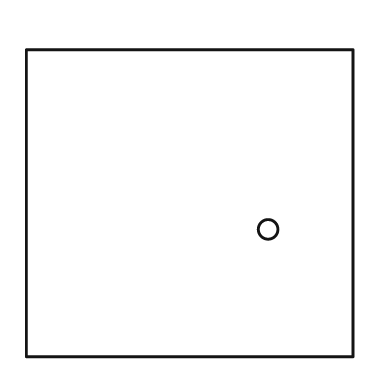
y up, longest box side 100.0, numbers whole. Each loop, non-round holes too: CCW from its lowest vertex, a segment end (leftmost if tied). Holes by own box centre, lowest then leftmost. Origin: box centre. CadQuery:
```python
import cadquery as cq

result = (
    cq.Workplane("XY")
    .moveTo(-50.0, -47.0)
    .lineTo(50.0, -47.0)
    .lineTo(50.0, 47.0)
    .lineTo(-50.0, 47.0)
    .close()
    .moveTo(24.0, -8.0)
    .circle(3.0)
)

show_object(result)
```